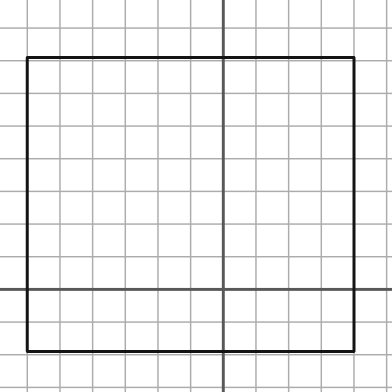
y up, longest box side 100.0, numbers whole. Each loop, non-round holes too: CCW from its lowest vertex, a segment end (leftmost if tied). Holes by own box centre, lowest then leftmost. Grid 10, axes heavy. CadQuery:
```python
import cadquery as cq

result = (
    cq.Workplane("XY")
    .moveTo(-60.0, -19.0)
    .lineTo(40.0, -19.0)
    .lineTo(40.0, 71.0)
    .lineTo(-60.0, 71.0)
    .close()
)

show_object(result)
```